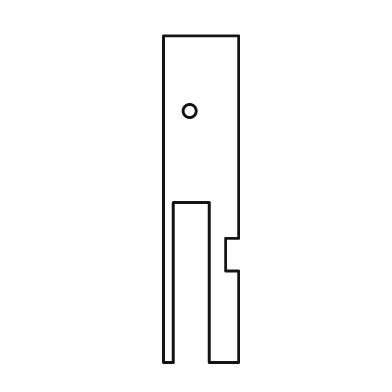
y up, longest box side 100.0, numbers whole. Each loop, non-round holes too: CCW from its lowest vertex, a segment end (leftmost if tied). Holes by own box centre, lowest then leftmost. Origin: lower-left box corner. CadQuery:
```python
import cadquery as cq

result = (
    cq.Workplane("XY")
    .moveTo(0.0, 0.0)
    .lineTo(3.0, 0.0)
    .lineTo(3.0, 49.0)
    .lineTo(14.0, 49.0)
    .lineTo(14.0, 0.0)
    .lineTo(23.0, 0.0)
    .lineTo(23.0, 28.0)
    .lineTo(19.0, 28.0)
    .lineTo(19.0, 38.0)
    .lineTo(23.0, 38.0)
    .lineTo(23.0, 100.0)
    .lineTo(0.0, 100.0)
    .close()
    .moveTo(8.0, 77.0)
    .circle(2.0)
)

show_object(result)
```